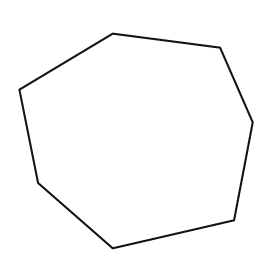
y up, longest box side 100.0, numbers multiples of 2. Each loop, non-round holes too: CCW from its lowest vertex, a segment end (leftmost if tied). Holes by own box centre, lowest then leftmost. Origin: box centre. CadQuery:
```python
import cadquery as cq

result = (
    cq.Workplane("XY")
    .moveTo(-10.0, -46.0)
    .lineTo(42.0, -34.0)
    .lineTo(50.0, 8.0)
    .lineTo(36.0, 40.0)
    .lineTo(-10.0, 46.0)
    .lineTo(-50.0, 22.0)
    .lineTo(-42.0, -18.0)
    .close()
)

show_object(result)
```